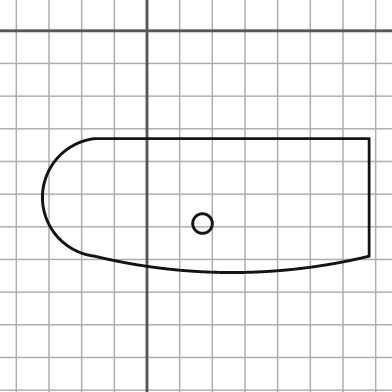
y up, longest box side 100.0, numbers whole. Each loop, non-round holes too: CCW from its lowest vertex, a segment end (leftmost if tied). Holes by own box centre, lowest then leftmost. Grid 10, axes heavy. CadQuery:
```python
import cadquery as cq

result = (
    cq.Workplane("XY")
    .moveTo(-16.0, -69.0)
    .threePointArc((26.0, -74.0), (68.0, -69.0))
    .lineTo(68.0, -33.0)
    .lineTo(-16.0, -33.0)
    .threePointArc((-32.0, -51.0), (-16.0, -69.0))
    .close()
    .moveTo(17.0, -59.0)
    .circle(3.0)
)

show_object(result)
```